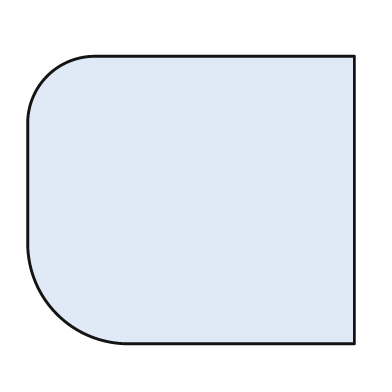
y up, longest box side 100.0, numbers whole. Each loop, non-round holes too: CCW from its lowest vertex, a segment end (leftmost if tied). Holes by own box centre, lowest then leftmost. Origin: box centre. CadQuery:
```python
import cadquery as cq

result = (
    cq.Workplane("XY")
    .moveTo(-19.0, -44.0)
    .lineTo(50.0, -44.0)
    .lineTo(50.0, 44.0)
    .lineTo(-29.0, 44.0)
    .threePointArc((-44.0, 38.0), (-50.0, 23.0))
    .lineTo(-50.0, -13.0)
    .threePointArc((-41.0, -35.0), (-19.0, -44.0))
    .close()
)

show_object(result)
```